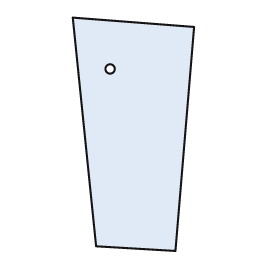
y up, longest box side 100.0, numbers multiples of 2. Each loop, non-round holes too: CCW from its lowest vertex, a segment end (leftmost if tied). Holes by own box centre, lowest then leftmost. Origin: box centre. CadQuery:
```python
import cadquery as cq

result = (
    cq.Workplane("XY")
    .moveTo(18.0, -50.0)
    .lineTo(26.0, 46.0)
    .lineTo(-26.0, 50.0)
    .lineTo(-16.0, -48.0)
    .close()
    .moveTo(-10.0, 28.0)
    .circle(2.0)
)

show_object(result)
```